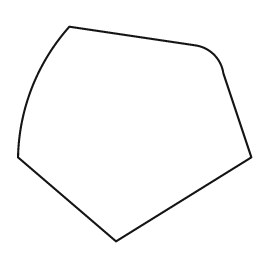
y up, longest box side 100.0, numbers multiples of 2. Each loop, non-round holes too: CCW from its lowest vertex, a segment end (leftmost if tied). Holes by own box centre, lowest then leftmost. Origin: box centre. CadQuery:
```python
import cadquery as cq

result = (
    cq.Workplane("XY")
    .moveTo(-8.0, -46.0)
    .lineTo(50.0, -10.0)
    .lineTo(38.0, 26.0)
    .threePointArc((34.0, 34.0), (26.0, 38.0))
    .lineTo(-28.0, 46.0)
    .threePointArc((-44.0, 20.0), (-50.0, -10.0))
    .close()
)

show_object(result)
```